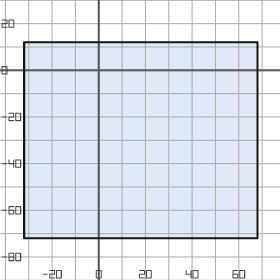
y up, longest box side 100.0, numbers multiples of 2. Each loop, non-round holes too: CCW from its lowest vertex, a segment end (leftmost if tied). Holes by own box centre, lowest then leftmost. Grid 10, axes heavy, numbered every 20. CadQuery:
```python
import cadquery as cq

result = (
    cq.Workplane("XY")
    .moveTo(-32.0, -72.0)
    .lineTo(68.0, -72.0)
    .lineTo(68.0, 12.0)
    .lineTo(-32.0, 12.0)
    .close()
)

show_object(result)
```